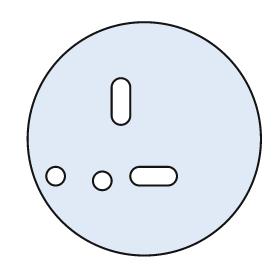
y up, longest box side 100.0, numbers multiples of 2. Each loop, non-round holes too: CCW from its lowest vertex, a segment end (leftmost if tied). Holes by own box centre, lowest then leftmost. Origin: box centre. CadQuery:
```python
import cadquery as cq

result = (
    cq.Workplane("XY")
    .moveTo(0.0, 0.0)
    .circle(50.0)
    .moveTo(-18.0, -18.0)
    .circle(4.0)
    .moveTo(-38.0, -16.0)
    .circle(4.0)
    .moveTo(-2.0, -20.0)
    .lineTo(10.0, -20.0)
    .threePointArc((14.0, -16.0), (10.0, -12.0))
    .lineTo(-2.0, -12.0)
    .threePointArc((-6.0, -16.0), (-2.0, -20.0))
    .close()
    .moveTo(-14.0, 10.0)
    .threePointArc((-10.0, 6.0), (-6.0, 10.0))
    .lineTo(-6.0, 22.0)
    .threePointArc((-10.0, 26.0), (-14.0, 22.0))
    .close()
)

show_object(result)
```